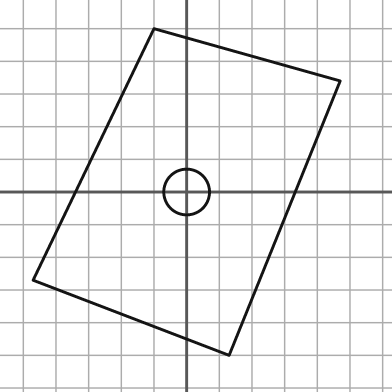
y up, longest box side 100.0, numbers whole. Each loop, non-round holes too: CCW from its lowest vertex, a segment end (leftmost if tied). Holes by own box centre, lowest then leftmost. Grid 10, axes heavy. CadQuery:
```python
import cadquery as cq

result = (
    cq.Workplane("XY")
    .moveTo(13.0, -50.0)
    .lineTo(47.0, 34.0)
    .lineTo(-10.0, 50.0)
    .lineTo(-47.0, -27.0)
    .close()
    .moveTo(0.0, 0.0)
    .circle(7.0)
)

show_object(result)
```